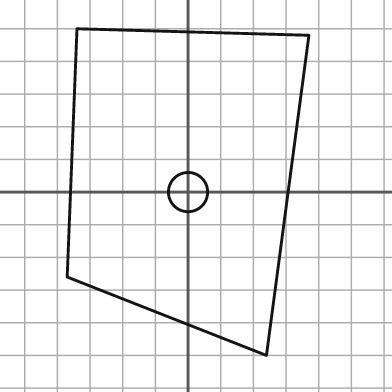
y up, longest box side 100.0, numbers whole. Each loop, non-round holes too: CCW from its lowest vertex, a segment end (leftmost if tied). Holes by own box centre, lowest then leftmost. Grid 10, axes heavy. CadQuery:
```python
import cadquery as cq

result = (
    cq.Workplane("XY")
    .moveTo(24.0, -50.0)
    .lineTo(37.0, 48.0)
    .lineTo(-34.0, 50.0)
    .lineTo(-37.0, -26.0)
    .close()
    .moveTo(0.0, 0.0)
    .circle(6.0)
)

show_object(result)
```